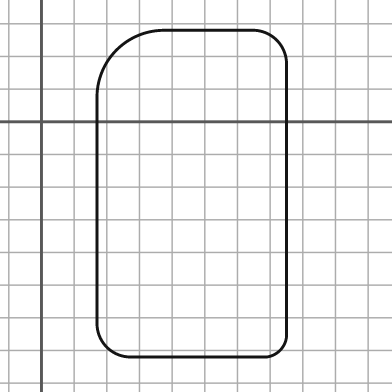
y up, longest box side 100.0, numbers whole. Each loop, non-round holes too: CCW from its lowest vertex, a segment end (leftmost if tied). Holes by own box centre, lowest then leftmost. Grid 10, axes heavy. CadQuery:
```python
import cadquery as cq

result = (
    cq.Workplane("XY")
    .moveTo(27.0, -72.0)
    .lineTo(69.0, -72.0)
    .threePointArc((73.0, -70.0), (75.0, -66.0))
    .lineTo(75.0, 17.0)
    .threePointArc((72.0, 25.0), (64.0, 28.0))
    .lineTo(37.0, 28.0)
    .threePointArc((23.0, 22.0), (17.0, 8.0))
    .lineTo(17.0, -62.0)
    .threePointArc((20.0, -69.0), (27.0, -72.0))
    .close()
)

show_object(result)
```